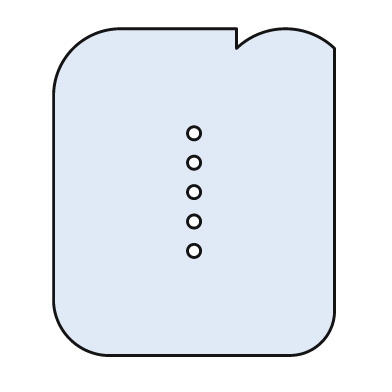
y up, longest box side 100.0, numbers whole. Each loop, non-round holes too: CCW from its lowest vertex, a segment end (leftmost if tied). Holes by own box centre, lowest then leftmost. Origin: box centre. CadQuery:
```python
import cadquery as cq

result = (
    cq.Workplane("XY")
    .moveTo(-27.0, -50.0)
    .lineTo(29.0, -50.0)
    .threePointArc((39.0, -46.0), (43.0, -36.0))
    .lineTo(43.0, 44.0)
    .threePointArc((28.0, 50.0), (13.0, 44.0))
    .lineTo(13.0, 50.0)
    .lineTo(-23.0, 50.0)
    .threePointArc((-37.0, 44.0), (-43.0, 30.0))
    .lineTo(-43.0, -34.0)
    .threePointArc((-38.0, -45.0), (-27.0, -50.0))
    .close()
    .moveTo(0.0, -18.0)
    .circle(2.0)
    .moveTo(0.0, -9.0)
    .circle(2.0)
    .moveTo(0.0, 0.0)
    .circle(2.0)
    .moveTo(0.0, 9.0)
    .circle(2.0)
    .moveTo(0.0, 18.0)
    .circle(2.0)
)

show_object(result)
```